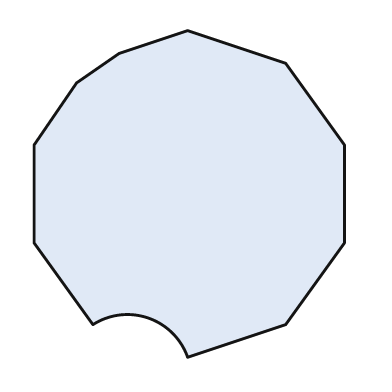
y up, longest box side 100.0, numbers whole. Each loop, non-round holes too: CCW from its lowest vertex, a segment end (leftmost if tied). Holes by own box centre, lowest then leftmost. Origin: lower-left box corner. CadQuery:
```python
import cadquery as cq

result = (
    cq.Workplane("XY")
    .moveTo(47.0, 0.0)
    .lineTo(77.0, 10.0)
    .lineTo(95.0, 35.0)
    .lineTo(95.0, 65.0)
    .lineTo(77.0, 90.0)
    .lineTo(47.0, 100.0)
    .lineTo(26.0, 93.0)
    .lineTo(13.0, 84.0)
    .lineTo(0.0, 65.0)
    .lineTo(0.0, 35.0)
    .lineTo(18.0, 10.0)
    .threePointArc((35.0, 12.0), (47.0, 0.0))
    .close()
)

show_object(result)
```